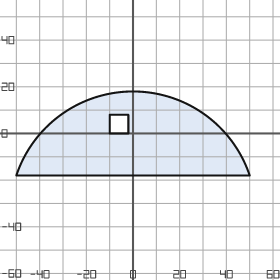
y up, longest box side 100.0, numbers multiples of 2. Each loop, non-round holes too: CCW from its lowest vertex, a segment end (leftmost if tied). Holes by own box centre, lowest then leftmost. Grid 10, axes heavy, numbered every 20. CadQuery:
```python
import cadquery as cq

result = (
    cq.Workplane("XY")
    .moveTo(-50.0, -18.0)
    .lineTo(50.0, -18.0)
    .threePointArc((0.0, 18.0), (-50.0, -18.0))
    .close()
    .moveTo(-10.0, 0.0)
    .lineTo(-2.0, 0.0)
    .lineTo(-2.0, 8.0)
    .lineTo(-10.0, 8.0)
    .close()
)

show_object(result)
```